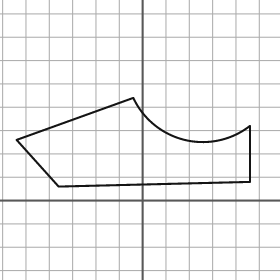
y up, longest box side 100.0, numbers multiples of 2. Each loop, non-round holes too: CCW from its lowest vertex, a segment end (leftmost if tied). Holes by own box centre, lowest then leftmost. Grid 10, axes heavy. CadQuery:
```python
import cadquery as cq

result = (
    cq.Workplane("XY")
    .moveTo(-36.0, 6.0)
    .lineTo(46.0, 8.0)
    .lineTo(46.0, 32.0)
    .threePointArc((18.0, 26.0), (-4.0, 44.0))
    .lineTo(-54.0, 26.0)
    .close()
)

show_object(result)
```